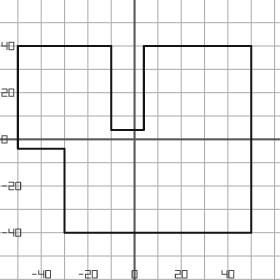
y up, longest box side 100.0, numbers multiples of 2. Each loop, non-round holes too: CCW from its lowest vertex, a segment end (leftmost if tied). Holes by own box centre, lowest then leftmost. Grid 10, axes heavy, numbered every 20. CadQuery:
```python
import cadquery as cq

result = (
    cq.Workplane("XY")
    .moveTo(-30.0, -40.0)
    .lineTo(50.0, -40.0)
    .lineTo(50.0, 40.0)
    .lineTo(4.0, 40.0)
    .lineTo(4.0, 4.0)
    .lineTo(-10.0, 4.0)
    .lineTo(-10.0, 40.0)
    .lineTo(-50.0, 40.0)
    .lineTo(-50.0, -4.0)
    .lineTo(-30.0, -4.0)
    .close()
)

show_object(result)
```